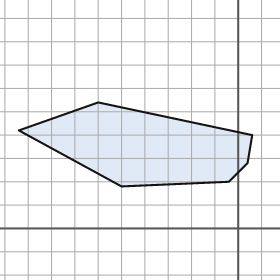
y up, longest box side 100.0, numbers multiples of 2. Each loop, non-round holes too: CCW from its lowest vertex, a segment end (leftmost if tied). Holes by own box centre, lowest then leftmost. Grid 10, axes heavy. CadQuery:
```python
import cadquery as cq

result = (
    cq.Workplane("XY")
    .moveTo(-50.0, 18.0)
    .lineTo(-4.0, 20.0)
    .lineTo(4.0, 28.0)
    .lineTo(6.0, 40.0)
    .lineTo(-60.0, 54.0)
    .lineTo(-94.0, 42.0)
    .close()
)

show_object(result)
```